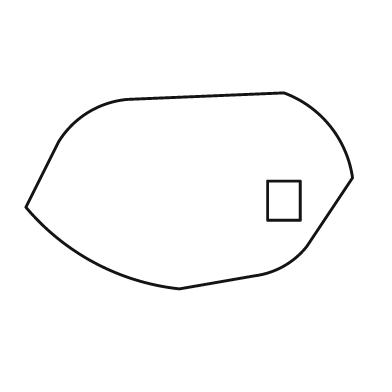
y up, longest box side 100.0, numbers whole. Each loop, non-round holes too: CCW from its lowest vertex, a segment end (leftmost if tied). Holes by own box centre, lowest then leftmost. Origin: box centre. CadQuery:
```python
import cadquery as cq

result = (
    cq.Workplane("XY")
    .moveTo(-3.0, -30.0)
    .lineTo(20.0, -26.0)
    .threePointArc((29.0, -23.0), (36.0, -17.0))
    .lineTo(50.0, 4.0)
    .threePointArc((43.0, 20.0), (29.0, 30.0))
    .lineTo(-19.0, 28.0)
    .threePointArc((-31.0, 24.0), (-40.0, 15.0))
    .lineTo(-50.0, -5.0)
    .threePointArc((-29.0, -22.0), (-3.0, -30.0))
    .close()
    .moveTo(24.0, -9.0)
    .lineTo(34.0, -9.0)
    .lineTo(34.0, 3.0)
    .lineTo(24.0, 3.0)
    .close()
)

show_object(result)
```